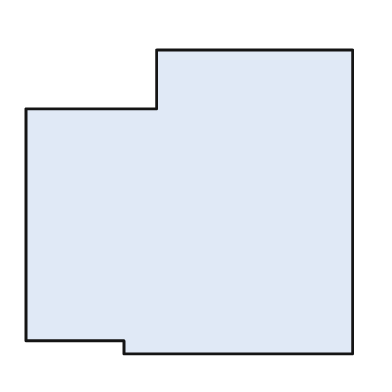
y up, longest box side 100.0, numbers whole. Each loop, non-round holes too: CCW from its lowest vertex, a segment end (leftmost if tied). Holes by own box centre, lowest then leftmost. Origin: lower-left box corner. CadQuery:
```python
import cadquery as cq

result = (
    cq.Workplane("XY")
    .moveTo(30.0, 0.0)
    .lineTo(100.0, 0.0)
    .lineTo(100.0, 93.0)
    .lineTo(40.0, 93.0)
    .lineTo(40.0, 75.0)
    .lineTo(0.0, 75.0)
    .lineTo(0.0, 4.0)
    .lineTo(30.0, 4.0)
    .close()
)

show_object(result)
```